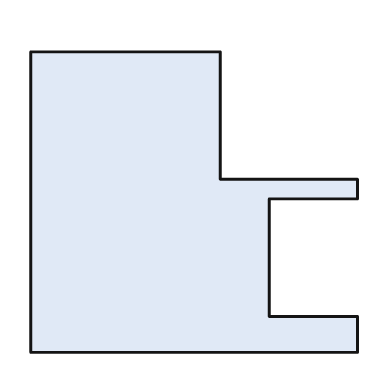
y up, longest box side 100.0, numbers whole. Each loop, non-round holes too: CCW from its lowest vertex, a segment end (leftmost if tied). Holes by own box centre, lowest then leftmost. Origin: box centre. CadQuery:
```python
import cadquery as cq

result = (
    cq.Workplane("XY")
    .moveTo(-50.0, -46.0)
    .lineTo(50.0, -46.0)
    .lineTo(50.0, -35.0)
    .lineTo(23.0, -35.0)
    .lineTo(23.0, 1.0)
    .lineTo(50.0, 1.0)
    .lineTo(50.0, 7.0)
    .lineTo(8.0, 7.0)
    .lineTo(8.0, 46.0)
    .lineTo(-50.0, 46.0)
    .close()
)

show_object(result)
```